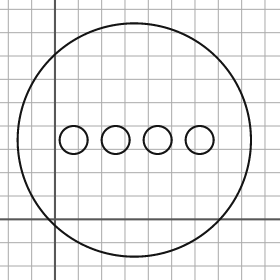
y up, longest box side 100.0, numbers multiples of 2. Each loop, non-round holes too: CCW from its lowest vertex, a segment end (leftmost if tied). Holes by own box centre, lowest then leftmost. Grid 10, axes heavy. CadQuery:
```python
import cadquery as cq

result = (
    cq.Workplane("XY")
    .moveTo(34.0, 34.0)
    .circle(50.0)
    .moveTo(8.0, 34.0)
    .circle(6.0)
    .moveTo(26.0, 34.0)
    .circle(6.0)
    .moveTo(44.0, 34.0)
    .circle(6.0)
    .moveTo(62.0, 34.0)
    .circle(6.0)
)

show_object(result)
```